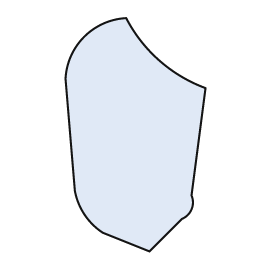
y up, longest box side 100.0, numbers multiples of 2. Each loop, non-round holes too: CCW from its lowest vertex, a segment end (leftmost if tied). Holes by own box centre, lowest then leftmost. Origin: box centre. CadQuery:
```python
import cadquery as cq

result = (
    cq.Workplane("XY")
    .moveTo(6.0, -50.0)
    .lineTo(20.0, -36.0)
    .threePointArc((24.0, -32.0), (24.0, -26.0))
    .lineTo(30.0, 20.0)
    .threePointArc((10.0, 32.0), (-4.0, 50.0))
    .threePointArc((-22.0, 42.0), (-30.0, 24.0))
    .lineTo(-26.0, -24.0)
    .threePointArc((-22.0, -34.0), (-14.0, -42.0))
    .close()
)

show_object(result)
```